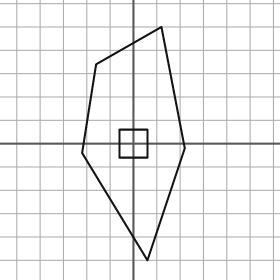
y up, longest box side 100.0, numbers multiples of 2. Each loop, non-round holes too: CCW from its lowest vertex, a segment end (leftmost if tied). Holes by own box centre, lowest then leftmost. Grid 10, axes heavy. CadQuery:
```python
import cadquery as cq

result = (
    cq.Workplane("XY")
    .moveTo(6.0, -50.0)
    .lineTo(22.0, -2.0)
    .lineTo(12.0, 50.0)
    .lineTo(-16.0, 34.0)
    .lineTo(-22.0, -4.0)
    .close()
    .moveTo(-6.0, -6.0)
    .lineTo(6.0, -6.0)
    .lineTo(6.0, 6.0)
    .lineTo(-6.0, 6.0)
    .close()
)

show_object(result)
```